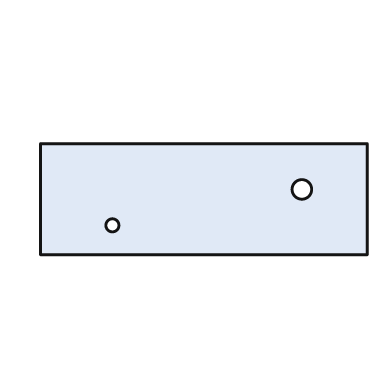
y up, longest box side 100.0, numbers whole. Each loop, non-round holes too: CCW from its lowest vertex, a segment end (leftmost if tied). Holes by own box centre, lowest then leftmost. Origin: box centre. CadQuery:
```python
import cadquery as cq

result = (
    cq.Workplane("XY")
    .moveTo(-50.0, -17.0)
    .lineTo(50.0, -17.0)
    .lineTo(50.0, 17.0)
    .lineTo(-50.0, 17.0)
    .close()
    .moveTo(-28.0, -8.0)
    .circle(2.0)
    .moveTo(30.0, 3.0)
    .circle(3.0)
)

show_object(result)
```